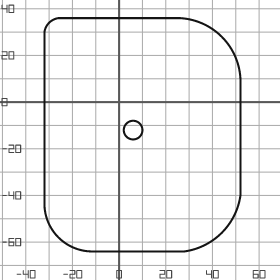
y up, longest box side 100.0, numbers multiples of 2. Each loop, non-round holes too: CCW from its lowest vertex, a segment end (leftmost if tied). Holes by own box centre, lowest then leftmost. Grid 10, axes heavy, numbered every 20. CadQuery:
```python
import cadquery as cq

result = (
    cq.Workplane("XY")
    .moveTo(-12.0, -64.0)
    .lineTo(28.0, -64.0)
    .threePointArc((44.0, -56.0), (52.0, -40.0))
    .lineTo(52.0, 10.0)
    .threePointArc((44.0, 28.0), (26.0, 36.0))
    .lineTo(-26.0, 36.0)
    .threePointArc((-30.0, 34.0), (-32.0, 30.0))
    .lineTo(-32.0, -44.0)
    .threePointArc((-26.0, -58.0), (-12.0, -64.0))
    .close()
    .moveTo(6.0, -12.0)
    .circle(4.0)
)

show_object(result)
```